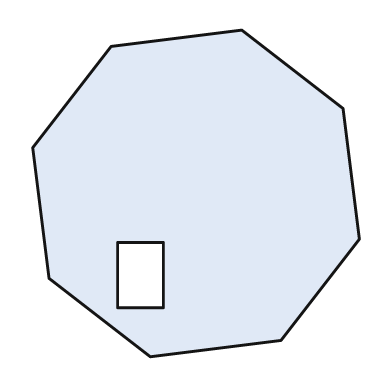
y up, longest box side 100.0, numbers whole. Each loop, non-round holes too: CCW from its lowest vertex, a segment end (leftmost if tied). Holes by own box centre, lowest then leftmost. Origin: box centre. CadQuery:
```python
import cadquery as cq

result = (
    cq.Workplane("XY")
    .moveTo(-14.0, -50.0)
    .lineTo(26.0, -45.0)
    .lineTo(50.0, -14.0)
    .lineTo(45.0, 26.0)
    .lineTo(14.0, 50.0)
    .lineTo(-26.0, 45.0)
    .lineTo(-50.0, 14.0)
    .lineTo(-45.0, -26.0)
    .close()
    .moveTo(-24.0, -35.0)
    .lineTo(-10.0, -35.0)
    .lineTo(-10.0, -15.0)
    .lineTo(-24.0, -15.0)
    .close()
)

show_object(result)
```